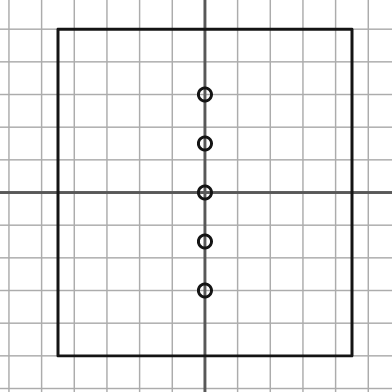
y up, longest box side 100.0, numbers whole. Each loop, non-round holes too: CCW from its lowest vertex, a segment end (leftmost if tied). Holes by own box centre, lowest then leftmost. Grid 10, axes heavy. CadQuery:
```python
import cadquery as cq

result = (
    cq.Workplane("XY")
    .moveTo(-45.0, -50.0)
    .lineTo(45.0, -50.0)
    .lineTo(45.0, 50.0)
    .lineTo(-45.0, 50.0)
    .close()
    .moveTo(0.0, -30.0)
    .circle(2.0)
    .moveTo(0.0, -15.0)
    .circle(2.0)
    .moveTo(0.0, 0.0)
    .circle(2.0)
    .moveTo(0.0, 15.0)
    .circle(2.0)
    .moveTo(0.0, 30.0)
    .circle(2.0)
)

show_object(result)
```